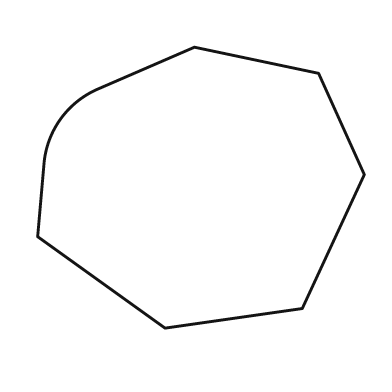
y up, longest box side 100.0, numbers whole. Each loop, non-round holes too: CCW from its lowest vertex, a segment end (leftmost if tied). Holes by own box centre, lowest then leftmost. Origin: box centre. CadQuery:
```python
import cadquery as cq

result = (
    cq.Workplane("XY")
    .moveTo(-11.0, -43.0)
    .lineTo(31.0, -37.0)
    .lineTo(50.0, 4.0)
    .lineTo(36.0, 35.0)
    .lineTo(-2.0, 43.0)
    .lineTo(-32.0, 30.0)
    .threePointArc((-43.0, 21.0), (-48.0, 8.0))
    .lineTo(-50.0, -15.0)
    .close()
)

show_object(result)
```